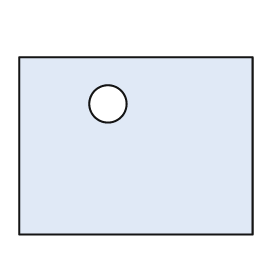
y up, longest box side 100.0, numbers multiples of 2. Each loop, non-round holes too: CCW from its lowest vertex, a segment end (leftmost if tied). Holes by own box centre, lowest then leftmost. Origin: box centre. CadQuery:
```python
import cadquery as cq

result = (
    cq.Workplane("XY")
    .moveTo(-50.0, -38.0)
    .lineTo(50.0, -38.0)
    .lineTo(50.0, 38.0)
    .lineTo(-50.0, 38.0)
    .close()
    .moveTo(-12.0, 18.0)
    .circle(8.0)
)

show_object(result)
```